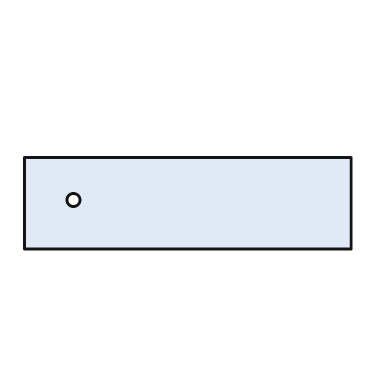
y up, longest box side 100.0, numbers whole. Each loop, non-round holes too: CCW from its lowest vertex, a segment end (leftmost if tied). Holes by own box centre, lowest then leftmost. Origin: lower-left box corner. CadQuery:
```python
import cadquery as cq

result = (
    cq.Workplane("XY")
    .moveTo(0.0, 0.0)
    .lineTo(100.0, 0.0)
    .lineTo(100.0, 28.0)
    .lineTo(0.0, 28.0)
    .close()
    .moveTo(15.0, 15.0)
    .circle(2.0)
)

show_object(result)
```